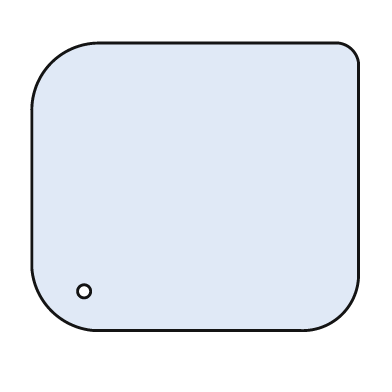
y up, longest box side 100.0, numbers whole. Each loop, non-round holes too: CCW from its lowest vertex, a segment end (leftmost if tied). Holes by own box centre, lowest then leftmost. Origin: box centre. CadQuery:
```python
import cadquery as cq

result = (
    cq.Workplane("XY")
    .moveTo(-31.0, -44.0)
    .lineTo(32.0, -44.0)
    .threePointArc((45.0, -39.0), (50.0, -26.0))
    .lineTo(50.0, 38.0)
    .threePointArc((48.0, 42.0), (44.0, 44.0))
    .lineTo(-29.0, 44.0)
    .threePointArc((-44.0, 38.0), (-50.0, 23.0))
    .lineTo(-50.0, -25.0)
    .threePointArc((-44.0, -38.0), (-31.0, -44.0))
    .close()
    .moveTo(-34.0, -32.0)
    .circle(2.0)
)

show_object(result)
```